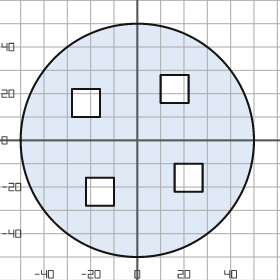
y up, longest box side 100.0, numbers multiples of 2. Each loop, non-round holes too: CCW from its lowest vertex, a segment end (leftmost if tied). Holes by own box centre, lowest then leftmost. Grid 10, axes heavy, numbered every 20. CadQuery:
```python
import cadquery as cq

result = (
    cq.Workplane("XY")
    .moveTo(0.0, 0.0)
    .circle(50.0)
    .moveTo(-22.0, -28.0)
    .lineTo(-10.0, -28.0)
    .lineTo(-10.0, -16.0)
    .lineTo(-22.0, -16.0)
    .close()
    .moveTo(16.0, -22.0)
    .lineTo(28.0, -22.0)
    .lineTo(28.0, -10.0)
    .lineTo(16.0, -10.0)
    .close()
    .moveTo(-28.0, 10.0)
    .lineTo(-16.0, 10.0)
    .lineTo(-16.0, 22.0)
    .lineTo(-28.0, 22.0)
    .close()
    .moveTo(10.0, 16.0)
    .lineTo(22.0, 16.0)
    .lineTo(22.0, 28.0)
    .lineTo(10.0, 28.0)
    .close()
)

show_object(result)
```